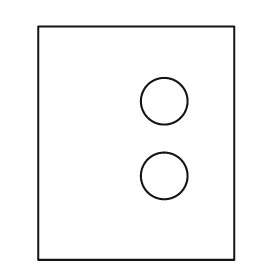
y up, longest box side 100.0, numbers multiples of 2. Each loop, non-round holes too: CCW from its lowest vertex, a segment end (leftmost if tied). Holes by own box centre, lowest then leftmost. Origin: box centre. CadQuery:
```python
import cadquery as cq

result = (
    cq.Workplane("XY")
    .moveTo(-42.0, -50.0)
    .lineTo(42.0, -50.0)
    .lineTo(42.0, 50.0)
    .lineTo(-42.0, 50.0)
    .close()
    .moveTo(12.0, -14.0)
    .circle(10.0)
    .moveTo(12.0, 18.0)
    .circle(10.0)
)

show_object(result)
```